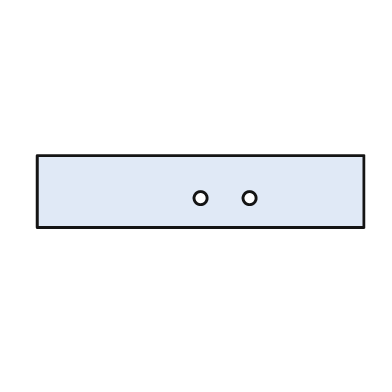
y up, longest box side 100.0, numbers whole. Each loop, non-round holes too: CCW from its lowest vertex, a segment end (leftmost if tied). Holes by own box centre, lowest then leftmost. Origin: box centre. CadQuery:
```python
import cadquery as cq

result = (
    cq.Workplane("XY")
    .moveTo(-50.0, -11.0)
    .lineTo(50.0, -11.0)
    .lineTo(50.0, 11.0)
    .lineTo(-50.0, 11.0)
    .close()
    .moveTo(0.0, -2.0)
    .circle(2.0)
    .moveTo(15.0, -2.0)
    .circle(2.0)
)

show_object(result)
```